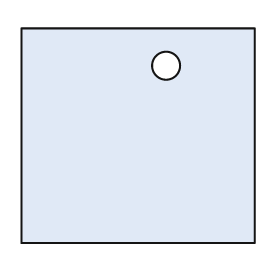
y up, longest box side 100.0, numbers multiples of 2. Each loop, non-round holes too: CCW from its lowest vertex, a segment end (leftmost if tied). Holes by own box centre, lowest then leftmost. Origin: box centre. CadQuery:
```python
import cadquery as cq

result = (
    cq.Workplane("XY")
    .moveTo(-50.0, -46.0)
    .lineTo(50.0, -46.0)
    .lineTo(50.0, 46.0)
    .lineTo(-50.0, 46.0)
    .close()
    .moveTo(12.0, 30.0)
    .circle(6.0)
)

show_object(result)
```